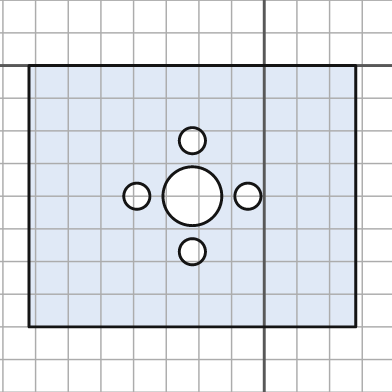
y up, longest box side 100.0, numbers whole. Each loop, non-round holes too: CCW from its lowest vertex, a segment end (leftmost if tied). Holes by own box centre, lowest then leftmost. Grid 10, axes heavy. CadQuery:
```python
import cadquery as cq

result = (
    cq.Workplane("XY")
    .moveTo(-72.0, -80.0)
    .lineTo(28.0, -80.0)
    .lineTo(28.0, 0.0)
    .lineTo(-72.0, 0.0)
    .close()
    .moveTo(-22.0, -57.0)
    .circle(4.0)
    .moveTo(-39.0, -40.0)
    .circle(4.0)
    .moveTo(-22.0, -40.0)
    .circle(9.0)
    .moveTo(-5.0, -40.0)
    .circle(4.0)
    .moveTo(-22.0, -23.0)
    .circle(4.0)
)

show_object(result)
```